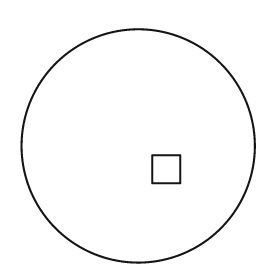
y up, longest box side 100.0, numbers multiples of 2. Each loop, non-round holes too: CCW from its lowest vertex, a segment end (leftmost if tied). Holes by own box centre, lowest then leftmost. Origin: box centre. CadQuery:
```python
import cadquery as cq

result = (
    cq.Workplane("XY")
    .moveTo(0.0, 0.0)
    .circle(50.0)
    .moveTo(6.0, -16.0)
    .lineTo(18.0, -16.0)
    .lineTo(18.0, -4.0)
    .lineTo(6.0, -4.0)
    .close()
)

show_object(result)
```